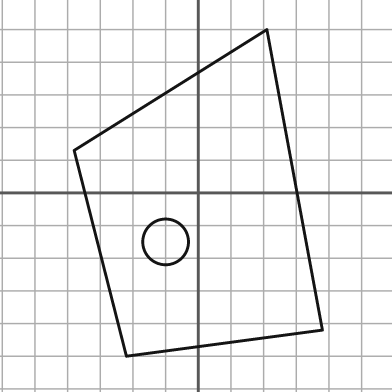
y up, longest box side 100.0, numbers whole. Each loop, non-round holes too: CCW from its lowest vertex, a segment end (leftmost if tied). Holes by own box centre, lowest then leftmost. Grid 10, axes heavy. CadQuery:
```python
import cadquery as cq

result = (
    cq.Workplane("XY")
    .moveTo(-22.0, -50.0)
    .lineTo(38.0, -42.0)
    .lineTo(21.0, 50.0)
    .lineTo(-38.0, 13.0)
    .close()
    .moveTo(-10.0, -15.0)
    .circle(7.0)
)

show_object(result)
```